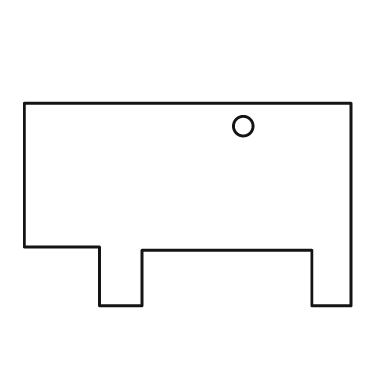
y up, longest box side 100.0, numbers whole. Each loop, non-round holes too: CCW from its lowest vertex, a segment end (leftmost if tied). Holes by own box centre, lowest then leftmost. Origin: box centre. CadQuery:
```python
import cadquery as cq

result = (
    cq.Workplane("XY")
    .moveTo(-27.0, -31.0)
    .lineTo(-14.0, -31.0)
    .lineTo(-14.0, -14.0)
    .lineTo(38.0, -14.0)
    .lineTo(38.0, -31.0)
    .lineTo(50.0, -31.0)
    .lineTo(50.0, 31.0)
    .lineTo(-50.0, 31.0)
    .lineTo(-50.0, -13.0)
    .lineTo(-27.0, -13.0)
    .close()
    .moveTo(17.0, 24.0)
    .circle(3.0)
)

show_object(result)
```